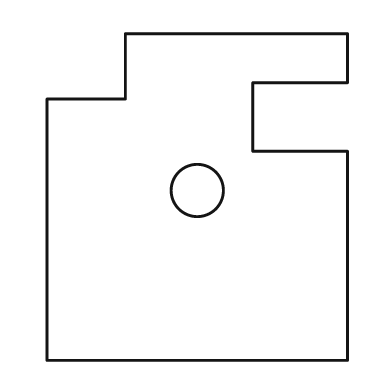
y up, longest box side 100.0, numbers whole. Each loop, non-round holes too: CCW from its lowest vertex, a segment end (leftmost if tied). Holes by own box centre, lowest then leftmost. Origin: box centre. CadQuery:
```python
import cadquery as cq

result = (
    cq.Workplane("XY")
    .moveTo(-46.0, -50.0)
    .lineTo(46.0, -50.0)
    .lineTo(46.0, 14.0)
    .lineTo(17.0, 14.0)
    .lineTo(17.0, 35.0)
    .lineTo(46.0, 35.0)
    .lineTo(46.0, 50.0)
    .lineTo(-22.0, 50.0)
    .lineTo(-22.0, 30.0)
    .lineTo(-46.0, 30.0)
    .close()
    .moveTo(0.0, 2.0)
    .circle(8.0)
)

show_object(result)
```